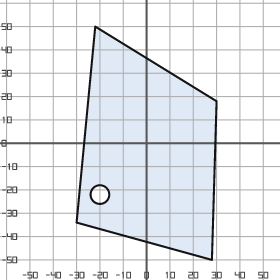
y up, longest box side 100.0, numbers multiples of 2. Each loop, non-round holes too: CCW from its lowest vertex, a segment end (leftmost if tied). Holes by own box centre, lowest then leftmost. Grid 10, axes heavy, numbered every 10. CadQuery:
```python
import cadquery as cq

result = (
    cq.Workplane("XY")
    .moveTo(28.0, -50.0)
    .lineTo(30.0, 18.0)
    .lineTo(-22.0, 50.0)
    .lineTo(-30.0, -34.0)
    .close()
    .moveTo(-20.0, -22.0)
    .circle(4.0)
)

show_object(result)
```